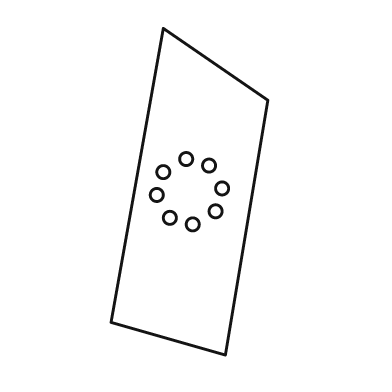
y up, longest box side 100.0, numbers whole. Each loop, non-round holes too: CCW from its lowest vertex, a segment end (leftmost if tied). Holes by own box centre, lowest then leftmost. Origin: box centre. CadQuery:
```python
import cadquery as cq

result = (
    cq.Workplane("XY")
    .moveTo(11.0, -50.0)
    .lineTo(24.0, 28.0)
    .lineTo(-8.0, 50.0)
    .lineTo(-24.0, -40.0)
    .close()
    .moveTo(1.0, -10.0)
    .circle(2.0)
    .moveTo(-6.0, -8.0)
    .circle(2.0)
    .moveTo(8.0, -6.0)
    .circle(2.0)
    .moveTo(-10.0, -1.0)
    .circle(2.0)
    .moveTo(10.0, 1.0)
    .circle(2.0)
    .moveTo(-8.0, 6.0)
    .circle(2.0)
    .moveTo(6.0, 8.0)
    .circle(2.0)
    .moveTo(-1.0, 10.0)
    .circle(2.0)
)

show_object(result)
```